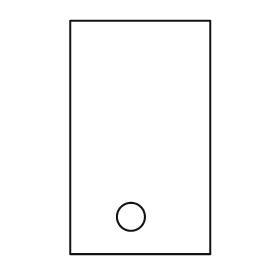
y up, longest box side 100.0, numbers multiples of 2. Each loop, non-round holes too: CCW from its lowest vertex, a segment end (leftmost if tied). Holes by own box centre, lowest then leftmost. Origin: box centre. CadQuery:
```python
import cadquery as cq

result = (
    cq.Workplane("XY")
    .moveTo(-30.0, -50.0)
    .lineTo(30.0, -50.0)
    .lineTo(30.0, 50.0)
    .lineTo(-30.0, 50.0)
    .close()
    .moveTo(-4.0, -34.0)
    .circle(6.0)
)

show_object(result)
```